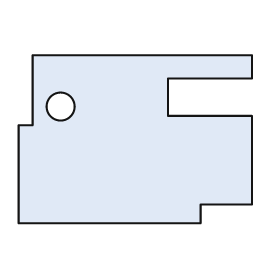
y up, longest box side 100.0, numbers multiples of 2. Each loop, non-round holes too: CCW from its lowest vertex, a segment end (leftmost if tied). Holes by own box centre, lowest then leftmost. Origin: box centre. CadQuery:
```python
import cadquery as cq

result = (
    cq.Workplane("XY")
    .moveTo(-50.0, -36.0)
    .lineTo(28.0, -36.0)
    .lineTo(28.0, -28.0)
    .lineTo(50.0, -28.0)
    .lineTo(50.0, 10.0)
    .lineTo(14.0, 10.0)
    .lineTo(14.0, 26.0)
    .lineTo(50.0, 26.0)
    .lineTo(50.0, 36.0)
    .lineTo(-44.0, 36.0)
    .lineTo(-44.0, 6.0)
    .lineTo(-50.0, 6.0)
    .close()
    .moveTo(-32.0, 14.0)
    .circle(6.0)
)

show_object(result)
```